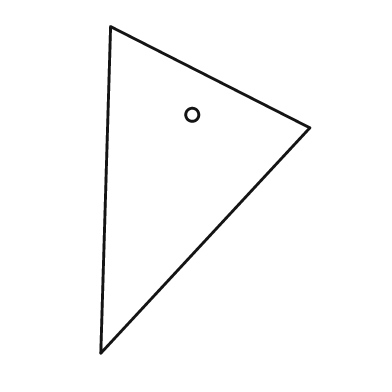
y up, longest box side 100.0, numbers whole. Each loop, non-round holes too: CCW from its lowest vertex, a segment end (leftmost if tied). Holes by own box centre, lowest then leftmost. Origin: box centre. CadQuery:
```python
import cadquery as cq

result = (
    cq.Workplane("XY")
    .moveTo(-32.0, -50.0)
    .lineTo(32.0, 19.0)
    .lineTo(-29.0, 50.0)
    .close()
    .moveTo(-4.0, 23.0)
    .circle(2.0)
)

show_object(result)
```